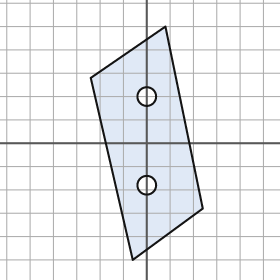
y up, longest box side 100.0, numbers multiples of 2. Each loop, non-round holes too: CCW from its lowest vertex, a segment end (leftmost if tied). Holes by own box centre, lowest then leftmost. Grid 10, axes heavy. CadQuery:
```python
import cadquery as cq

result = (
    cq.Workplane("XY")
    .moveTo(-6.0, -50.0)
    .lineTo(24.0, -28.0)
    .lineTo(8.0, 50.0)
    .lineTo(-24.0, 28.0)
    .close()
    .moveTo(0.0, -18.0)
    .circle(4.0)
    .moveTo(0.0, 20.0)
    .circle(4.0)
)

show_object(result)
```